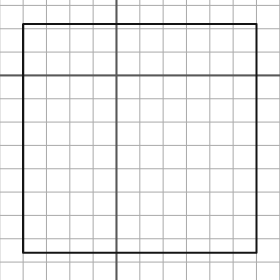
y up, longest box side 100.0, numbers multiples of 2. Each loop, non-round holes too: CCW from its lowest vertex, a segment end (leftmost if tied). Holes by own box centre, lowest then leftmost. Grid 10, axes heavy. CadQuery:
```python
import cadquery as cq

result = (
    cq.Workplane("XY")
    .moveTo(-40.0, -76.0)
    .lineTo(60.0, -76.0)
    .lineTo(60.0, 22.0)
    .lineTo(-40.0, 22.0)
    .close()
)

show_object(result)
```